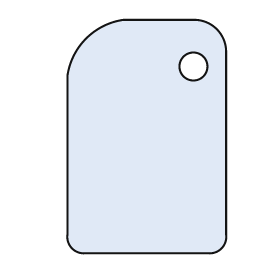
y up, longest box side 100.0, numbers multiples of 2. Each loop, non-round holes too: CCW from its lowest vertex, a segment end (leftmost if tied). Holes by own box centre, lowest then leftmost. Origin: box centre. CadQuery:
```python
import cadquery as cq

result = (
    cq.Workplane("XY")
    .moveTo(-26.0, -50.0)
    .lineTo(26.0, -50.0)
    .threePointArc((32.0, -48.0), (34.0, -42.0))
    .lineTo(34.0, 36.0)
    .threePointArc((30.0, 46.0), (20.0, 50.0))
    .lineTo(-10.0, 50.0)
    .threePointArc((-26.0, 42.0), (-34.0, 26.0))
    .lineTo(-34.0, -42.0)
    .threePointArc((-32.0, -48.0), (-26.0, -50.0))
    .close()
    .moveTo(20.0, 30.0)
    .circle(6.0)
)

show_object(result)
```